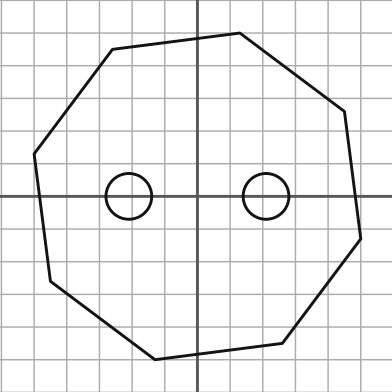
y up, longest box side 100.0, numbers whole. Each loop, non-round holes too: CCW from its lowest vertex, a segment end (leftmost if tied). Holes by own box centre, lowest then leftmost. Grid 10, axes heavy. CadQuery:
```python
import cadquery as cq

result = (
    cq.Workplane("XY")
    .moveTo(-13.0, -50.0)
    .lineTo(26.0, -45.0)
    .lineTo(50.0, -13.0)
    .lineTo(45.0, 26.0)
    .lineTo(13.0, 50.0)
    .lineTo(-26.0, 45.0)
    .lineTo(-50.0, 13.0)
    .lineTo(-45.0, -26.0)
    .close()
    .moveTo(-21.0, 0.0)
    .circle(7.0)
    .moveTo(21.0, 0.0)
    .circle(7.0)
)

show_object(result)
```